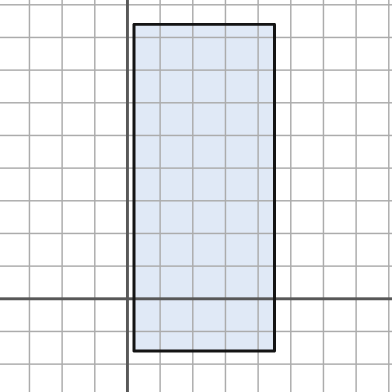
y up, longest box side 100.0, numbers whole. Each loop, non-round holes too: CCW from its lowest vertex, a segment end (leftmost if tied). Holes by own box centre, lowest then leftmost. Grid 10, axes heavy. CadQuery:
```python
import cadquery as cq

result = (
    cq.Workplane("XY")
    .moveTo(2.0, -16.0)
    .lineTo(45.0, -16.0)
    .lineTo(45.0, 84.0)
    .lineTo(2.0, 84.0)
    .close()
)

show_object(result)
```